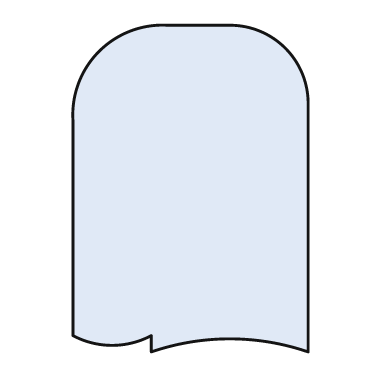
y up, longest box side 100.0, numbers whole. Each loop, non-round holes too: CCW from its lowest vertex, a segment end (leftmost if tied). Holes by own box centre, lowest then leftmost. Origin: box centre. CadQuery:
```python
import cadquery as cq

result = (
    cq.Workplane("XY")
    .moveTo(-12.0, -50.0)
    .threePointArc((12.0, -46.0), (36.0, -50.0))
    .lineTo(36.0, 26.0)
    .threePointArc((29.0, 43.0), (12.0, 50.0))
    .lineTo(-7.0, 50.0)
    .threePointArc((-28.0, 42.0), (-36.0, 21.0))
    .lineTo(-36.0, -45.0)
    .threePointArc((-24.0, -48.0), (-12.0, -45.0))
    .close()
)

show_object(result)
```